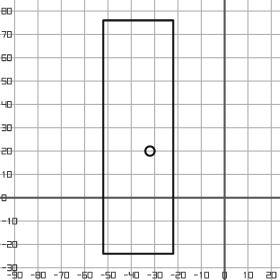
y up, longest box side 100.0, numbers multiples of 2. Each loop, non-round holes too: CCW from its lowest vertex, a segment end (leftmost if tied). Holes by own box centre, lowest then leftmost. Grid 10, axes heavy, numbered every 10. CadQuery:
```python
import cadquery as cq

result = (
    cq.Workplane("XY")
    .moveTo(-52.0, -24.0)
    .lineTo(-22.0, -24.0)
    .lineTo(-22.0, 76.0)
    .lineTo(-52.0, 76.0)
    .close()
    .moveTo(-32.0, 20.0)
    .circle(2.0)
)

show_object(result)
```